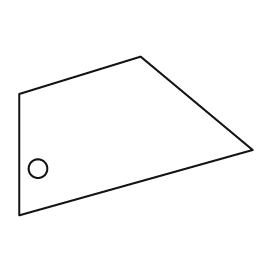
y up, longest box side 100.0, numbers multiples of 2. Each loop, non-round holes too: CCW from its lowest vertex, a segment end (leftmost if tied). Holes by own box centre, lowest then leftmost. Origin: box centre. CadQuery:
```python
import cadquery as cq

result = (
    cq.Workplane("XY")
    .moveTo(-50.0, -34.0)
    .lineTo(50.0, -6.0)
    .lineTo(2.0, 34.0)
    .lineTo(-50.0, 18.0)
    .close()
    .moveTo(-42.0, -14.0)
    .circle(4.0)
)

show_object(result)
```